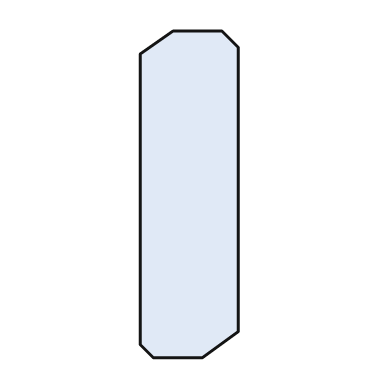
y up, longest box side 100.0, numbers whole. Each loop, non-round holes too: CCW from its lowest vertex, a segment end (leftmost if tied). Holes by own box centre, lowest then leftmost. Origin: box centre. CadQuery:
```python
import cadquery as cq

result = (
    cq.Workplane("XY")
    .moveTo(-11.0, -50.0)
    .lineTo(4.0, -50.0)
    .lineTo(15.0, -42.0)
    .lineTo(15.0, 45.0)
    .lineTo(10.0, 50.0)
    .lineTo(-5.0, 50.0)
    .lineTo(-15.0, 43.0)
    .lineTo(-15.0, -46.0)
    .close()
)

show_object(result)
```